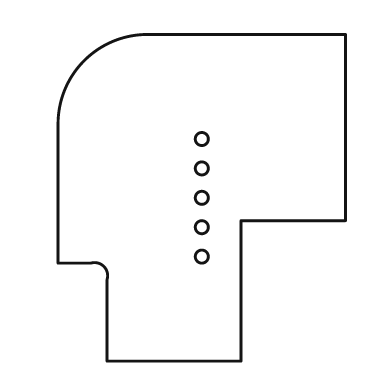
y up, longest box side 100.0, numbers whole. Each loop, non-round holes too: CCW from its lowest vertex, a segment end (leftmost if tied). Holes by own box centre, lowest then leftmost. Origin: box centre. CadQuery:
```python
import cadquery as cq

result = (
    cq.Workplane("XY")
    .moveTo(-29.0, -50.0)
    .lineTo(12.0, -50.0)
    .lineTo(12.0, -7.0)
    .lineTo(44.0, -7.0)
    .lineTo(44.0, 50.0)
    .lineTo(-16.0, 50.0)
    .threePointArc((-36.0, 42.0), (-44.0, 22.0))
    .lineTo(-44.0, -20.0)
    .lineTo(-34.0, -20.0)
    .threePointArc((-30.0, -21.0), (-29.0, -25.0))
    .close()
    .moveTo(0.0, -18.0)
    .circle(2.0)
    .moveTo(0.0, -9.0)
    .circle(2.0)
    .moveTo(0.0, 0.0)
    .circle(2.0)
    .moveTo(0.0, 9.0)
    .circle(2.0)
    .moveTo(0.0, 18.0)
    .circle(2.0)
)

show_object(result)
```